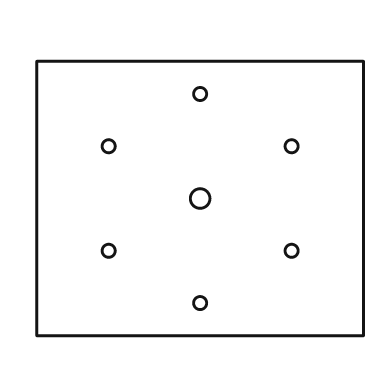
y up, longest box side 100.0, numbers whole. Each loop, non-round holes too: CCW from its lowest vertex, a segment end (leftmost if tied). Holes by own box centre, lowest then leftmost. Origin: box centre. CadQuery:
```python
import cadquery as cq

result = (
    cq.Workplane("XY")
    .moveTo(-50.0, -42.0)
    .lineTo(50.0, -42.0)
    .lineTo(50.0, 42.0)
    .lineTo(-50.0, 42.0)
    .close()
    .moveTo(0.0, -32.0)
    .circle(2.0)
    .moveTo(-28.0, -16.0)
    .circle(2.0)
    .moveTo(28.0, -16.0)
    .circle(2.0)
    .moveTo(0.0, 0.0)
    .circle(3.0)
    .moveTo(-28.0, 16.0)
    .circle(2.0)
    .moveTo(28.0, 16.0)
    .circle(2.0)
    .moveTo(0.0, 32.0)
    .circle(2.0)
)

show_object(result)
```